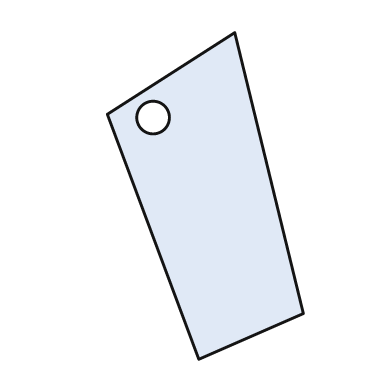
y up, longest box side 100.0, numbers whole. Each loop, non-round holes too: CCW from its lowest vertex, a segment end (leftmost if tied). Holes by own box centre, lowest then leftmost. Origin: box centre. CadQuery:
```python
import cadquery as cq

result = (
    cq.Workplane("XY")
    .moveTo(-2.0, -50.0)
    .lineTo(30.0, -36.0)
    .lineTo(9.0, 50.0)
    .lineTo(-30.0, 25.0)
    .close()
    .moveTo(-16.0, 24.0)
    .circle(5.0)
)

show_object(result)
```